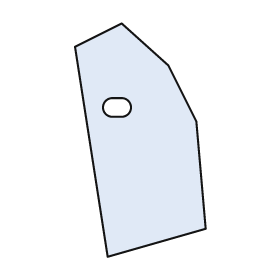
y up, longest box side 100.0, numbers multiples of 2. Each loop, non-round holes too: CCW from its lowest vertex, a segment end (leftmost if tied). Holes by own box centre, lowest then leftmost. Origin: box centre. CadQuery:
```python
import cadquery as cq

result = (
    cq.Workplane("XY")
    .moveTo(-14.0, -50.0)
    .lineTo(28.0, -38.0)
    .lineTo(24.0, 8.0)
    .lineTo(12.0, 32.0)
    .lineTo(-8.0, 50.0)
    .lineTo(-28.0, 40.0)
    .close()
    .moveTo(-12.0, 10.0)
    .lineTo(-8.0, 10.0)
    .threePointArc((-4.0, 14.0), (-8.0, 18.0))
    .lineTo(-12.0, 18.0)
    .threePointArc((-16.0, 14.0), (-12.0, 10.0))
    .close()
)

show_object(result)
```